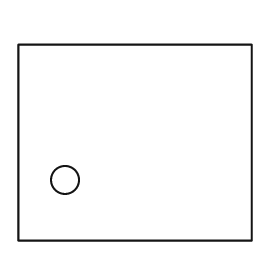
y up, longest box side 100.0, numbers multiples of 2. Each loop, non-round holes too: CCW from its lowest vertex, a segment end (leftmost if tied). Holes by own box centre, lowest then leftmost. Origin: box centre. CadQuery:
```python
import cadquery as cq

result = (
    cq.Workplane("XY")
    .moveTo(-50.0, -42.0)
    .lineTo(50.0, -42.0)
    .lineTo(50.0, 42.0)
    .lineTo(-50.0, 42.0)
    .close()
    .moveTo(-30.0, -16.0)
    .circle(6.0)
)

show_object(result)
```